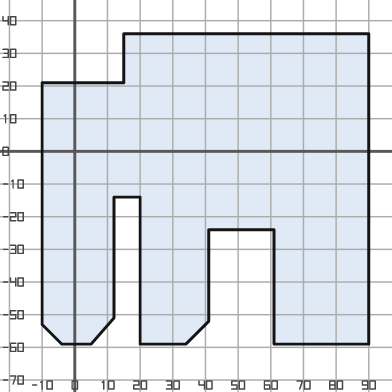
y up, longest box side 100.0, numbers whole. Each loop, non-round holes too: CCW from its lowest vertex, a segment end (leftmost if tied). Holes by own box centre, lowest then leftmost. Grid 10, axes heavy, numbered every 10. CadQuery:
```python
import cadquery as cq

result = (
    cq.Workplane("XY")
    .moveTo(-4.0, -59.0)
    .lineTo(5.0, -59.0)
    .lineTo(12.0, -51.0)
    .lineTo(12.0, -14.0)
    .lineTo(20.0, -14.0)
    .lineTo(20.0, -59.0)
    .lineTo(34.0, -59.0)
    .lineTo(41.0, -52.0)
    .lineTo(41.0, -24.0)
    .lineTo(61.0, -24.0)
    .lineTo(61.0, -59.0)
    .lineTo(90.0, -59.0)
    .lineTo(90.0, 36.0)
    .lineTo(15.0, 36.0)
    .lineTo(15.0, 21.0)
    .lineTo(-10.0, 21.0)
    .lineTo(-10.0, -53.0)
    .close()
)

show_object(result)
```